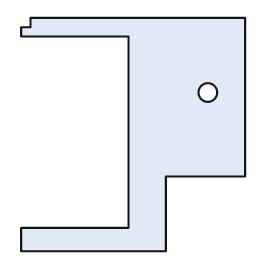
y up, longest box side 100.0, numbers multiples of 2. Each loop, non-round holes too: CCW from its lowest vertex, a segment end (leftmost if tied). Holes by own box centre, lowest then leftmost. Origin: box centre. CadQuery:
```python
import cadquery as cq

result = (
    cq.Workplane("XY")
    .moveTo(-48.0, -50.0)
    .lineTo(14.0, -50.0)
    .lineTo(14.0, -18.0)
    .lineTo(48.0, -18.0)
    .lineTo(48.0, 50.0)
    .lineTo(-44.0, 50.0)
    .lineTo(-44.0, 46.0)
    .lineTo(-48.0, 46.0)
    .lineTo(-48.0, 42.0)
    .lineTo(-2.0, 42.0)
    .lineTo(-2.0, -40.0)
    .lineTo(-48.0, -40.0)
    .close()
    .moveTo(32.0, 18.0)
    .circle(4.0)
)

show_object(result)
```